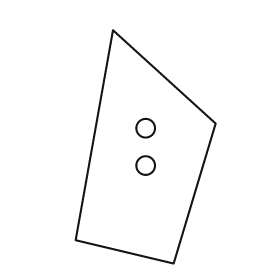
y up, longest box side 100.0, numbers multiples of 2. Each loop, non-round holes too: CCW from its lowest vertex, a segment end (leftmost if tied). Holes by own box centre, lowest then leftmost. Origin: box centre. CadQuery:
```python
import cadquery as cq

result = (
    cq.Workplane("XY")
    .moveTo(12.0, -50.0)
    .lineTo(30.0, 10.0)
    .lineTo(-14.0, 50.0)
    .lineTo(-30.0, -40.0)
    .close()
    .moveTo(0.0, -8.0)
    .circle(4.0)
    .moveTo(0.0, 8.0)
    .circle(4.0)
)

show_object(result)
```